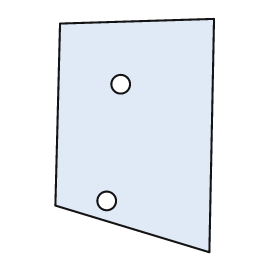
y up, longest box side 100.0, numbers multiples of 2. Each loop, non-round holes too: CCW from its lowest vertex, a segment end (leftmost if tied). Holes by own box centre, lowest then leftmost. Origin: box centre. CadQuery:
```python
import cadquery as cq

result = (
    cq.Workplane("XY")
    .moveTo(32.0, -50.0)
    .lineTo(34.0, 50.0)
    .lineTo(-32.0, 48.0)
    .lineTo(-34.0, -30.0)
    .close()
    .moveTo(-12.0, -28.0)
    .circle(4.0)
    .moveTo(-6.0, 22.0)
    .circle(4.0)
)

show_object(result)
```